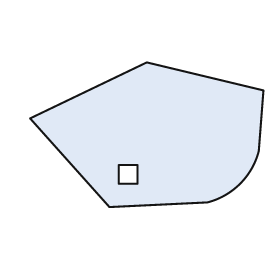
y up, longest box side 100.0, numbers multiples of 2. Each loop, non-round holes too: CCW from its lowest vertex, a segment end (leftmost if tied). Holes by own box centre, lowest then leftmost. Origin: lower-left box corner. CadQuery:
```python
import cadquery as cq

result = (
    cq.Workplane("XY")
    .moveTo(34.0, 0.0)
    .lineTo(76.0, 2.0)
    .threePointArc((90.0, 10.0), (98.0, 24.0))
    .lineTo(100.0, 50.0)
    .lineTo(50.0, 62.0)
    .lineTo(0.0, 38.0)
    .close()
    .moveTo(38.0, 10.0)
    .lineTo(46.0, 10.0)
    .lineTo(46.0, 18.0)
    .lineTo(38.0, 18.0)
    .close()
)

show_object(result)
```